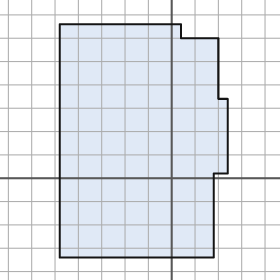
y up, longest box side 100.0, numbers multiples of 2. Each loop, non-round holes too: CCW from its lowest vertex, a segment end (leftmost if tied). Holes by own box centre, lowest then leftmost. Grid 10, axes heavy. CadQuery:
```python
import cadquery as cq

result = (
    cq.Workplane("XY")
    .moveTo(-48.0, -34.0)
    .lineTo(18.0, -34.0)
    .lineTo(18.0, 2.0)
    .lineTo(24.0, 2.0)
    .lineTo(24.0, 34.0)
    .lineTo(20.0, 34.0)
    .lineTo(20.0, 60.0)
    .lineTo(4.0, 60.0)
    .lineTo(4.0, 66.0)
    .lineTo(-48.0, 66.0)
    .close()
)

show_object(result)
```